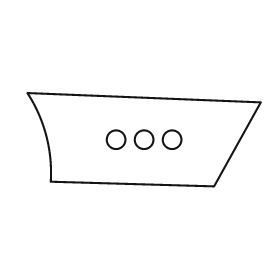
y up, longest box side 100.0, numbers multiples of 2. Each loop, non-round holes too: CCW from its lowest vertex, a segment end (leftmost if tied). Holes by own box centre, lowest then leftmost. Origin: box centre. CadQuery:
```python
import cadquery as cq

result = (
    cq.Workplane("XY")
    .moveTo(30.0, -20.0)
    .lineTo(50.0, 16.0)
    .lineTo(-50.0, 20.0)
    .threePointArc((-42.0, 2.0), (-40.0, -18.0))
    .close()
    .moveTo(-12.0, 0.0)
    .circle(4.0)
    .moveTo(0.0, 0.0)
    .circle(4.0)
    .moveTo(12.0, 0.0)
    .circle(4.0)
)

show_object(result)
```